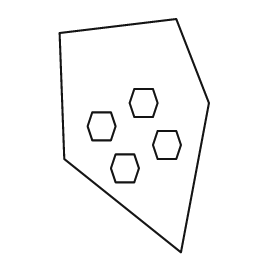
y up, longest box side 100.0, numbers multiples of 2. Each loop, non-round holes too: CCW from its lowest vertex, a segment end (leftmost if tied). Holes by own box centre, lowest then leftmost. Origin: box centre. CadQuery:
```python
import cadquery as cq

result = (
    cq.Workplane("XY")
    .moveTo(20.0, -50.0)
    .lineTo(32.0, 14.0)
    .lineTo(18.0, 50.0)
    .lineTo(-32.0, 44.0)
    .lineTo(-30.0, -10.0)
    .close()
    .moveTo(-8.0, -20.0)
    .lineTo(0.0, -20.0)
    .lineTo(2.0, -14.0)
    .lineTo(0.0, -8.0)
    .lineTo(-8.0, -8.0)
    .lineTo(-10.0, -14.0)
    .close()
    .moveTo(10.0, -10.0)
    .lineTo(18.0, -10.0)
    .lineTo(20.0, -4.0)
    .lineTo(18.0, 2.0)
    .lineTo(10.0, 2.0)
    .lineTo(8.0, -4.0)
    .close()
    .moveTo(-18.0, -2.0)
    .lineTo(-10.0, -2.0)
    .lineTo(-8.0, 4.0)
    .lineTo(-10.0, 10.0)
    .lineTo(-18.0, 10.0)
    .lineTo(-20.0, 4.0)
    .close()
    .moveTo(0.0, 8.0)
    .lineTo(8.0, 8.0)
    .lineTo(10.0, 14.0)
    .lineTo(8.0, 20.0)
    .lineTo(0.0, 20.0)
    .lineTo(-2.0, 14.0)
    .close()
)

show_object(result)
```